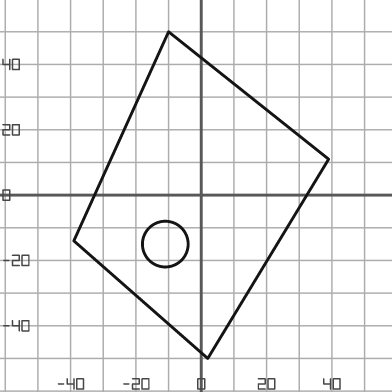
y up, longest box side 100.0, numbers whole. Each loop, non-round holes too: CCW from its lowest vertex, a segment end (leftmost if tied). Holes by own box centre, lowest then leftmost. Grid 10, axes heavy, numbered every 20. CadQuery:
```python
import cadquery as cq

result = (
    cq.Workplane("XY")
    .moveTo(2.0, -50.0)
    .lineTo(39.0, 11.0)
    .lineTo(-10.0, 50.0)
    .lineTo(-39.0, -14.0)
    .close()
    .moveTo(-11.0, -15.0)
    .circle(7.0)
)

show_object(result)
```